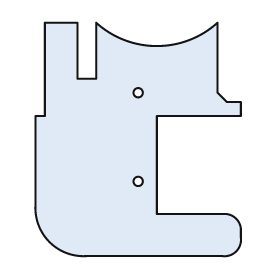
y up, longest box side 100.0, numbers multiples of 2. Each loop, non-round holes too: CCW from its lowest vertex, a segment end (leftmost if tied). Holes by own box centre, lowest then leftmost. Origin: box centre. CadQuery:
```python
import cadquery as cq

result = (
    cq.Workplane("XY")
    .moveTo(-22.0, -50.0)
    .lineTo(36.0, -50.0)
    .threePointArc((42.0, -48.0), (44.0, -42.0))
    .lineTo(44.0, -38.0)
    .threePointArc((42.0, -34.0), (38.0, -32.0))
    .lineTo(8.0, -32.0)
    .lineTo(8.0, 10.0)
    .lineTo(44.0, 10.0)
    .lineTo(44.0, 16.0)
    .lineTo(38.0, 16.0)
    .lineTo(34.0, 20.0)
    .lineTo(34.0, 50.0)
    .threePointArc((8.0, 40.0), (-18.0, 50.0))
    .lineTo(-18.0, 26.0)
    .lineTo(-26.0, 26.0)
    .lineTo(-26.0, 50.0)
    .lineTo(-40.0, 50.0)
    .lineTo(-40.0, 10.0)
    .lineTo(-44.0, 10.0)
    .lineTo(-44.0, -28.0)
    .threePointArc((-38.0, -44.0), (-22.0, -50.0))
    .close()
    .moveTo(0.0, -18.0)
    .circle(2.0)
    .moveTo(0.0, 20.0)
    .circle(2.0)
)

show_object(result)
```